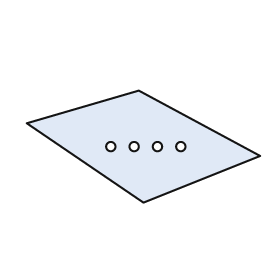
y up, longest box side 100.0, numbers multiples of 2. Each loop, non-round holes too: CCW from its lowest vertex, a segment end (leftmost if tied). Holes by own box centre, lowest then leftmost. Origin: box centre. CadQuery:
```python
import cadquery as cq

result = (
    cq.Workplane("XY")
    .moveTo(0.0, -24.0)
    .lineTo(50.0, -4.0)
    .lineTo(-2.0, 24.0)
    .lineTo(-50.0, 10.0)
    .close()
    .moveTo(-14.0, 0.0)
    .circle(2.0)
    .moveTo(-4.0, 0.0)
    .circle(2.0)
    .moveTo(6.0, 0.0)
    .circle(2.0)
    .moveTo(16.0, 0.0)
    .circle(2.0)
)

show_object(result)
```